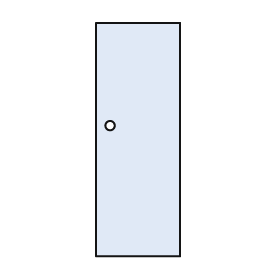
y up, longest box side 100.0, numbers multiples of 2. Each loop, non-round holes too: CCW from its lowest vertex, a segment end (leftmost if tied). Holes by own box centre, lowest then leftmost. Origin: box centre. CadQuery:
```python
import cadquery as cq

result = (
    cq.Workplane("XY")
    .moveTo(-18.0, -50.0)
    .lineTo(18.0, -50.0)
    .lineTo(18.0, 50.0)
    .lineTo(-18.0, 50.0)
    .close()
    .moveTo(-12.0, 6.0)
    .circle(2.0)
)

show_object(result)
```